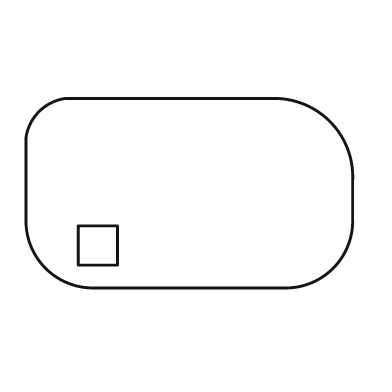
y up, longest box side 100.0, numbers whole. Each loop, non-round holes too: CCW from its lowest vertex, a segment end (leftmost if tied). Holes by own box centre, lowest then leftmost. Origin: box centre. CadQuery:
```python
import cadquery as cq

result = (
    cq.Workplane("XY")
    .moveTo(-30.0, -29.0)
    .lineTo(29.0, -29.0)
    .threePointArc((44.0, -23.0), (50.0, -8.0))
    .lineTo(50.0, 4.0)
    .threePointArc((43.0, 22.0), (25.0, 29.0))
    .lineTo(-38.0, 29.0)
    .threePointArc((-46.0, 25.0), (-50.0, 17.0))
    .lineTo(-50.0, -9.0)
    .threePointArc((-44.0, -23.0), (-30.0, -29.0))
    .close()
    .moveTo(-34.0, -22.0)
    .lineTo(-22.0, -22.0)
    .lineTo(-22.0, -10.0)
    .lineTo(-34.0, -10.0)
    .close()
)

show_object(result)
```